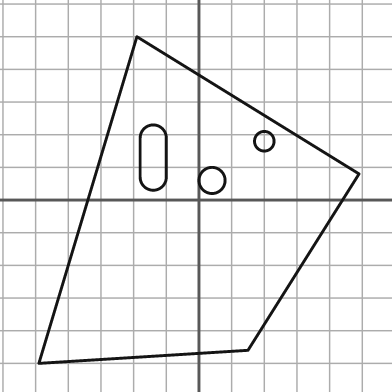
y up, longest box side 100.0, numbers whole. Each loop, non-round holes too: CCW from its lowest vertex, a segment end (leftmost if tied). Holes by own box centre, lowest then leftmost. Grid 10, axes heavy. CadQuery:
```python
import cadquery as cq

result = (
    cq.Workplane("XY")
    .moveTo(-49.0, -50.0)
    .lineTo(15.0, -46.0)
    .lineTo(49.0, 8.0)
    .lineTo(-19.0, 50.0)
    .close()
    .moveTo(4.0, 6.0)
    .circle(4.0)
    .moveTo(-18.0, 7.0)
    .threePointArc((-14.0, 3.0), (-10.0, 7.0))
    .lineTo(-10.0, 19.0)
    .threePointArc((-14.0, 23.0), (-18.0, 19.0))
    .close()
    .moveTo(20.0, 18.0)
    .circle(3.0)
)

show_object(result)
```